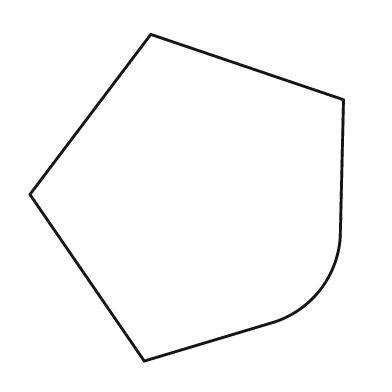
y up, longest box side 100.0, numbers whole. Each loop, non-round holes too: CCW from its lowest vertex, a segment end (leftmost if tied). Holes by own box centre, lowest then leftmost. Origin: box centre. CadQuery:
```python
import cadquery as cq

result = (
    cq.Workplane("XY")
    .moveTo(-13.0, -50.0)
    .lineTo(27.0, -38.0)
    .threePointArc((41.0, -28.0), (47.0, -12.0))
    .lineTo(48.0, 30.0)
    .lineTo(-11.0, 50.0)
    .lineTo(-48.0, 1.0)
    .close()
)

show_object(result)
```